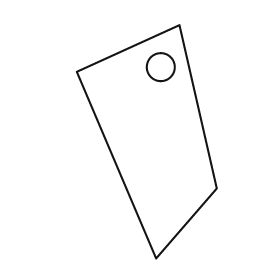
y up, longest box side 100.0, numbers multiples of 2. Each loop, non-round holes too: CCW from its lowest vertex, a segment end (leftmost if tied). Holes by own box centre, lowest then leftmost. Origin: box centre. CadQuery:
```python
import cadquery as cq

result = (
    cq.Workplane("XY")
    .moveTo(4.0, -50.0)
    .lineTo(30.0, -20.0)
    .lineTo(14.0, 50.0)
    .lineTo(-30.0, 30.0)
    .close()
    .moveTo(6.0, 32.0)
    .circle(6.0)
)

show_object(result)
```